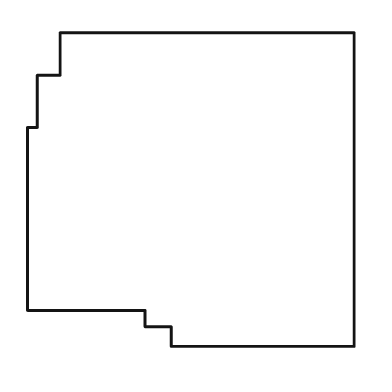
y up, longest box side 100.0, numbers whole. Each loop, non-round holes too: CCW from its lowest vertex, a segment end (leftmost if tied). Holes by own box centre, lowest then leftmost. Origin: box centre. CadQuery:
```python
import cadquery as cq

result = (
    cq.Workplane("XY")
    .moveTo(-6.0, -48.0)
    .lineTo(50.0, -48.0)
    .lineTo(50.0, 48.0)
    .lineTo(-40.0, 48.0)
    .lineTo(-40.0, 35.0)
    .lineTo(-47.0, 35.0)
    .lineTo(-47.0, 19.0)
    .lineTo(-50.0, 19.0)
    .lineTo(-50.0, -37.0)
    .lineTo(-14.0, -37.0)
    .lineTo(-14.0, -42.0)
    .lineTo(-6.0, -42.0)
    .close()
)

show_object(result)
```